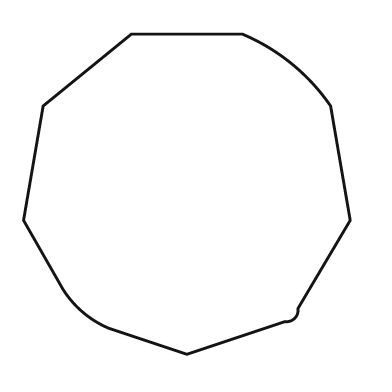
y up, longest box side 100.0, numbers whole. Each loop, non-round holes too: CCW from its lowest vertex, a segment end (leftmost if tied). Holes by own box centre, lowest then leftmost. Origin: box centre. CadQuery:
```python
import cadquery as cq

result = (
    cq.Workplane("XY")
    .moveTo(0.0, -49.0)
    .lineTo(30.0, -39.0)
    .threePointArc((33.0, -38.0), (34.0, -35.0))
    .lineTo(50.0, -8.0)
    .lineTo(44.0, 27.0)
    .threePointArc((32.0, 40.0), (17.0, 49.0))
    .lineTo(-17.0, 49.0)
    .lineTo(-44.0, 27.0)
    .lineTo(-50.0, -8.0)
    .lineTo(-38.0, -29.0)
    .threePointArc((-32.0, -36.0), (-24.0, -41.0))
    .close()
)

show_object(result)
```